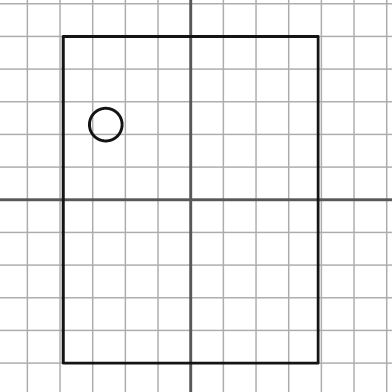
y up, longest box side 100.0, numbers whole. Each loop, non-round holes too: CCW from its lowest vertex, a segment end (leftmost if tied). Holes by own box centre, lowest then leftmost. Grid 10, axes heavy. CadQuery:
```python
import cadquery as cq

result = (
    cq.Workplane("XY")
    .moveTo(-39.0, -50.0)
    .lineTo(39.0, -50.0)
    .lineTo(39.0, 50.0)
    .lineTo(-39.0, 50.0)
    .close()
    .moveTo(-26.0, 23.0)
    .circle(5.0)
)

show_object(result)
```